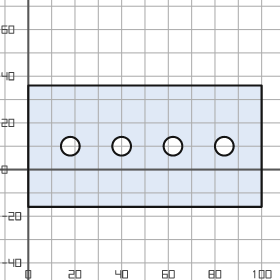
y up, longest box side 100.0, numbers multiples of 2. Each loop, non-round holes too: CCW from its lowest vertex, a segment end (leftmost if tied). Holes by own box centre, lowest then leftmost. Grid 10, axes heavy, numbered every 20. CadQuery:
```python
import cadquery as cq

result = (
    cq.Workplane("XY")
    .moveTo(0.0, -16.0)
    .lineTo(100.0, -16.0)
    .lineTo(100.0, 36.0)
    .lineTo(0.0, 36.0)
    .close()
    .moveTo(18.0, 10.0)
    .circle(4.0)
    .moveTo(40.0, 10.0)
    .circle(4.0)
    .moveTo(62.0, 10.0)
    .circle(4.0)
    .moveTo(84.0, 10.0)
    .circle(4.0)
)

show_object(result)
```